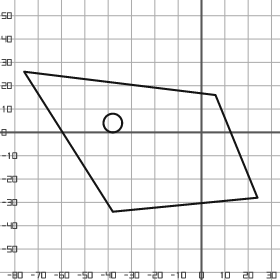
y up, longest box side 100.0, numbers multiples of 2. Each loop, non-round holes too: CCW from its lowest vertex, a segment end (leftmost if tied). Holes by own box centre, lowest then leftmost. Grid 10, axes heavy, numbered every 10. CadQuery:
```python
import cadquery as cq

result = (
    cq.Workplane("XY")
    .moveTo(-38.0, -34.0)
    .lineTo(24.0, -28.0)
    .lineTo(6.0, 16.0)
    .lineTo(-76.0, 26.0)
    .close()
    .moveTo(-38.0, 4.0)
    .circle(4.0)
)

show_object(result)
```